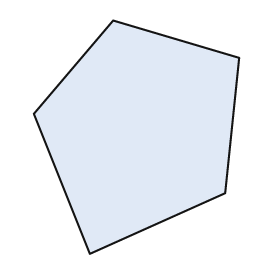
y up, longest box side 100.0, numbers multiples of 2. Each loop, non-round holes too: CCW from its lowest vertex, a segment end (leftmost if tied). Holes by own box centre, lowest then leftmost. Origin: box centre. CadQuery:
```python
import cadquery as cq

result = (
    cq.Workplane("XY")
    .moveTo(-20.0, -50.0)
    .lineTo(38.0, -24.0)
    .lineTo(44.0, 34.0)
    .lineTo(-10.0, 50.0)
    .lineTo(-44.0, 10.0)
    .close()
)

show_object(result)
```